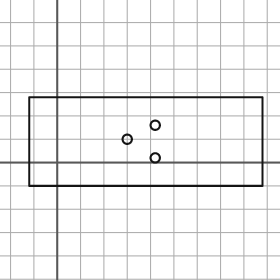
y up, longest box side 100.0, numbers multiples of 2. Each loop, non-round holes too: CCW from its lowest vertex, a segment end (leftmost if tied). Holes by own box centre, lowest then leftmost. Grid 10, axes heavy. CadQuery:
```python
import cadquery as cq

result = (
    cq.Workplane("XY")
    .moveTo(-12.0, -10.0)
    .lineTo(88.0, -10.0)
    .lineTo(88.0, 28.0)
    .lineTo(-12.0, 28.0)
    .close()
    .moveTo(42.0, 2.0)
    .circle(2.0)
    .moveTo(30.0, 10.0)
    .circle(2.0)
    .moveTo(42.0, 16.0)
    .circle(2.0)
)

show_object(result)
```